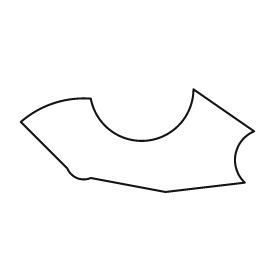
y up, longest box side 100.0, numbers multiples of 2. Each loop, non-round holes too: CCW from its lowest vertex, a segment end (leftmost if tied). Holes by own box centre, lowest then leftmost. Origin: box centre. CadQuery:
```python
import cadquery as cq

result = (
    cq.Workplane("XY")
    .moveTo(12.0, -22.0)
    .lineTo(46.0, -18.0)
    .threePointArc((42.0, -6.0), (50.0, 4.0))
    .lineTo(24.0, 22.0)
    .threePointArc((4.0, 0.0), (-20.0, 18.0))
    .threePointArc((-36.0, 16.0), (-50.0, 8.0))
    .lineTo(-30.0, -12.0)
    .threePointArc((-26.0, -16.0), (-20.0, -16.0))
    .close()
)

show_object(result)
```